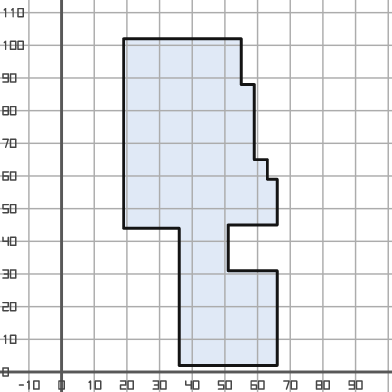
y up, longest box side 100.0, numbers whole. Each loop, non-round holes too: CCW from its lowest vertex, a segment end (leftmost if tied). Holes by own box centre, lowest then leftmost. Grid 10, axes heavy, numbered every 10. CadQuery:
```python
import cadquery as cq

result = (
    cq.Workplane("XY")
    .moveTo(36.0, 2.0)
    .lineTo(66.0, 2.0)
    .lineTo(66.0, 31.0)
    .lineTo(51.0, 31.0)
    .lineTo(51.0, 45.0)
    .lineTo(66.0, 45.0)
    .lineTo(66.0, 59.0)
    .lineTo(63.0, 59.0)
    .lineTo(63.0, 65.0)
    .lineTo(59.0, 65.0)
    .lineTo(59.0, 88.0)
    .lineTo(55.0, 88.0)
    .lineTo(55.0, 102.0)
    .lineTo(19.0, 102.0)
    .lineTo(19.0, 44.0)
    .lineTo(36.0, 44.0)
    .close()
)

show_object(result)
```